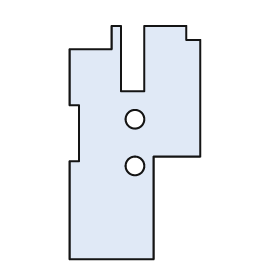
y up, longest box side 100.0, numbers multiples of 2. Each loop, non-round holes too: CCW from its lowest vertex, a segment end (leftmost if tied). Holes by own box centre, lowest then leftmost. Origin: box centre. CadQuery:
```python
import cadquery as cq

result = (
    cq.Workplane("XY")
    .moveTo(-28.0, -50.0)
    .lineTo(8.0, -50.0)
    .lineTo(8.0, -6.0)
    .lineTo(28.0, -6.0)
    .lineTo(28.0, 44.0)
    .lineTo(22.0, 44.0)
    .lineTo(22.0, 50.0)
    .lineTo(4.0, 50.0)
    .lineTo(4.0, 22.0)
    .lineTo(-6.0, 22.0)
    .lineTo(-6.0, 50.0)
    .lineTo(-10.0, 50.0)
    .lineTo(-10.0, 40.0)
    .lineTo(-28.0, 40.0)
    .lineTo(-28.0, 16.0)
    .lineTo(-24.0, 16.0)
    .lineTo(-24.0, -8.0)
    .lineTo(-28.0, -8.0)
    .close()
    .moveTo(0.0, -10.0)
    .circle(4.0)
    .moveTo(0.0, 10.0)
    .circle(4.0)
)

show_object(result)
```